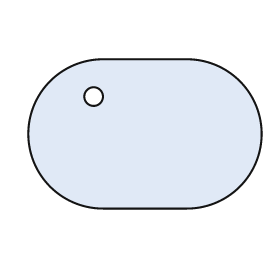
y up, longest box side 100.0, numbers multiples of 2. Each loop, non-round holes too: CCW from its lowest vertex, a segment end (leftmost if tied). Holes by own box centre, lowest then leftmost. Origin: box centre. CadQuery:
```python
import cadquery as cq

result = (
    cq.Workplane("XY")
    .moveTo(-18.0, -32.0)
    .lineTo(18.0, -32.0)
    .threePointArc((50.0, 0.0), (18.0, 32.0))
    .lineTo(-18.0, 32.0)
    .threePointArc((-50.0, 0.0), (-18.0, -32.0))
    .close()
    .moveTo(-22.0, 16.0)
    .circle(4.0)
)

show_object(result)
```